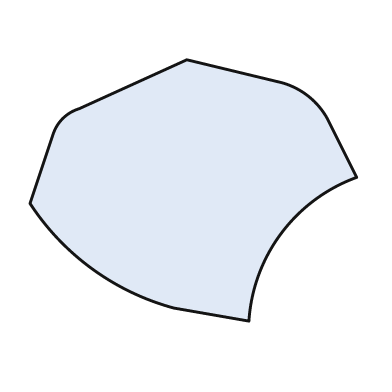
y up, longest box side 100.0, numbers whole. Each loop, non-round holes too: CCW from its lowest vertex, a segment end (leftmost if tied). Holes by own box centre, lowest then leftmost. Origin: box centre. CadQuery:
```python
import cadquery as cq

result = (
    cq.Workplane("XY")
    .moveTo(17.0, -40.0)
    .threePointArc((27.0, -13.0), (50.0, 4.0))
    .lineTo(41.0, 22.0)
    .threePointArc((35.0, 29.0), (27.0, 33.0))
    .lineTo(-2.0, 40.0)
    .lineTo(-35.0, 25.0)
    .threePointArc((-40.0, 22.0), (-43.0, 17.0))
    .lineTo(-50.0, -4.0)
    .threePointArc((-31.0, -24.0), (-6.0, -36.0))
    .close()
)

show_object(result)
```